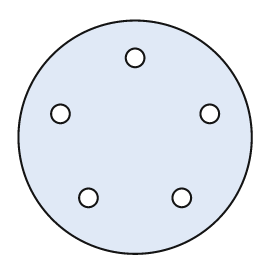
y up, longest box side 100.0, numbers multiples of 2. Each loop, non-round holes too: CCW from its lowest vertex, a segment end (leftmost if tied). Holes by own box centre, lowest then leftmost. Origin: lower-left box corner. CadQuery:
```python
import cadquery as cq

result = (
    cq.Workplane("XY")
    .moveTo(50.0, 50.0)
    .circle(50.0)
    .moveTo(30.0, 24.0)
    .circle(4.0)
    .moveTo(70.0, 24.0)
    .circle(4.0)
    .moveTo(18.0, 60.0)
    .circle(4.0)
    .moveTo(82.0, 60.0)
    .circle(4.0)
    .moveTo(50.0, 84.0)
    .circle(4.0)
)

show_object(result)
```